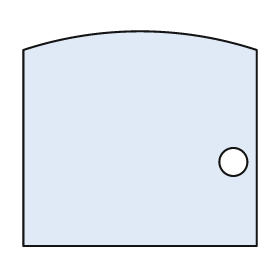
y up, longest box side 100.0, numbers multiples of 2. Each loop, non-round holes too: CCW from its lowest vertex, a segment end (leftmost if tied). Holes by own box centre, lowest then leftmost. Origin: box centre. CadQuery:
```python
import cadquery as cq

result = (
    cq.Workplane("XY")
    .moveTo(-50.0, -46.0)
    .lineTo(50.0, -46.0)
    .lineTo(50.0, 38.0)
    .threePointArc((0.0, 46.0), (-50.0, 38.0))
    .close()
    .moveTo(40.0, -10.0)
    .circle(6.0)
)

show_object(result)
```